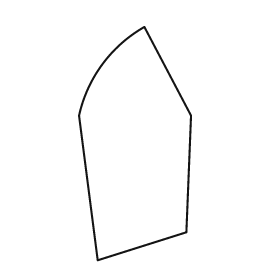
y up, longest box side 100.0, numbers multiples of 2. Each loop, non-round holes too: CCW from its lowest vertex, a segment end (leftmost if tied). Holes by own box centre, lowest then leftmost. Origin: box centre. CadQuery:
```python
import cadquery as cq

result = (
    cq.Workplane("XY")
    .moveTo(-16.0, -50.0)
    .lineTo(22.0, -38.0)
    .lineTo(24.0, 12.0)
    .lineTo(4.0, 50.0)
    .threePointArc((-14.0, 34.0), (-24.0, 12.0))
    .close()
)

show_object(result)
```